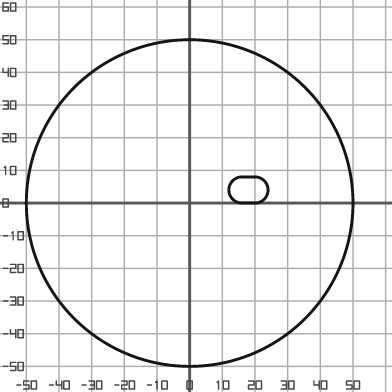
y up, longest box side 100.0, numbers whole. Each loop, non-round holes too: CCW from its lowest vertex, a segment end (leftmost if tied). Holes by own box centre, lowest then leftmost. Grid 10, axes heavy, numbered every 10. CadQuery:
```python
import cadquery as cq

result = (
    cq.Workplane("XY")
    .moveTo(0.0, 0.0)
    .circle(50.0)
    .moveTo(16.0, 0.0)
    .lineTo(20.0, 0.0)
    .threePointArc((24.0, 4.0), (20.0, 8.0))
    .lineTo(16.0, 8.0)
    .threePointArc((12.0, 4.0), (16.0, 0.0))
    .close()
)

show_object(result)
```